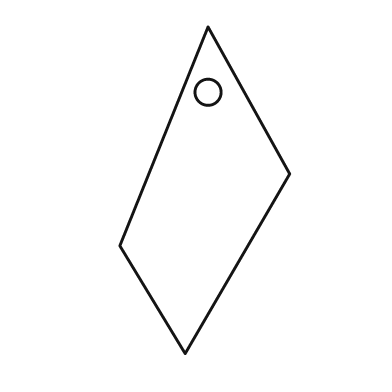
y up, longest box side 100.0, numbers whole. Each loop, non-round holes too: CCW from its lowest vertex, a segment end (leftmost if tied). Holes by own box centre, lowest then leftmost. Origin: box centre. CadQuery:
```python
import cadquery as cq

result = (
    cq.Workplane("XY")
    .moveTo(-6.0, -50.0)
    .lineTo(26.0, 5.0)
    .lineTo(1.0, 50.0)
    .lineTo(-26.0, -17.0)
    .close()
    .moveTo(1.0, 30.0)
    .circle(4.0)
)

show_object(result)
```